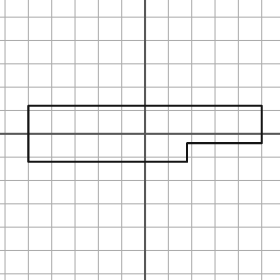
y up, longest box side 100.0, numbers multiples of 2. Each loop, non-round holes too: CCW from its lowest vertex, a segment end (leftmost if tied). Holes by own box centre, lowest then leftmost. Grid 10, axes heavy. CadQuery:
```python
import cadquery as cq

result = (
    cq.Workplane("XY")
    .moveTo(-50.0, -12.0)
    .lineTo(18.0, -12.0)
    .lineTo(18.0, -4.0)
    .lineTo(50.0, -4.0)
    .lineTo(50.0, 12.0)
    .lineTo(-50.0, 12.0)
    .close()
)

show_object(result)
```